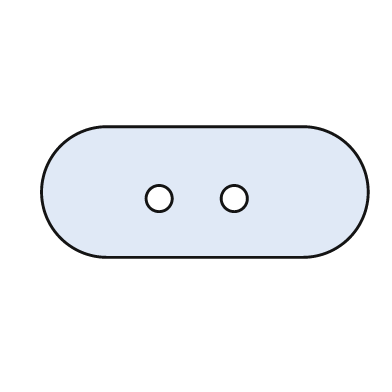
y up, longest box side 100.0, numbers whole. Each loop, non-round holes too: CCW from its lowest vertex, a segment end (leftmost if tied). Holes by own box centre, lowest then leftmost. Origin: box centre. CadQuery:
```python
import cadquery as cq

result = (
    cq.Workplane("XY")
    .moveTo(-30.0, -20.0)
    .lineTo(30.0, -20.0)
    .threePointArc((50.0, 0.0), (30.0, 20.0))
    .lineTo(-30.0, 20.0)
    .threePointArc((-50.0, 0.0), (-30.0, -20.0))
    .close()
    .moveTo(-14.0, -2.0)
    .circle(4.0)
    .moveTo(9.0, -2.0)
    .circle(4.0)
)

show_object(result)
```